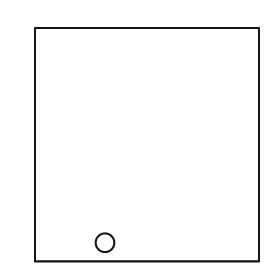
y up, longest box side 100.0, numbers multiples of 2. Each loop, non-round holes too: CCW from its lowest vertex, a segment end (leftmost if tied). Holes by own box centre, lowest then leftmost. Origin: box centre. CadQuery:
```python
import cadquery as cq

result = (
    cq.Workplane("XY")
    .moveTo(-48.0, -50.0)
    .lineTo(48.0, -50.0)
    .lineTo(48.0, 50.0)
    .lineTo(-48.0, 50.0)
    .close()
    .moveTo(-18.0, -42.0)
    .circle(4.0)
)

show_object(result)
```